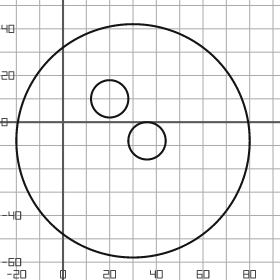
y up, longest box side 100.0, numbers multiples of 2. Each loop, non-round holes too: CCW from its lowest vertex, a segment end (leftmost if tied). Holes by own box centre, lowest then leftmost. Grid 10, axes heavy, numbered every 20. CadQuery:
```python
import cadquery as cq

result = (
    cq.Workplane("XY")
    .moveTo(30.0, -8.0)
    .circle(50.0)
    .moveTo(36.0, -8.0)
    .circle(8.0)
    .moveTo(20.0, 10.0)
    .circle(8.0)
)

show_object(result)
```